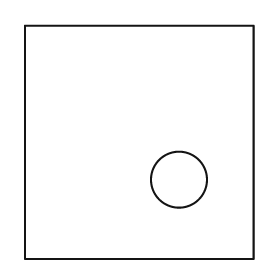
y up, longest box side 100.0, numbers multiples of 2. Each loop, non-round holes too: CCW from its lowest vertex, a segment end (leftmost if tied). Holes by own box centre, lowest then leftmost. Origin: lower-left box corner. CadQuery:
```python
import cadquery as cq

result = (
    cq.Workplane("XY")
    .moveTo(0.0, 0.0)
    .lineTo(98.0, 0.0)
    .lineTo(98.0, 100.0)
    .lineTo(0.0, 100.0)
    .close()
    .moveTo(66.0, 34.0)
    .circle(12.0)
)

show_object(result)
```